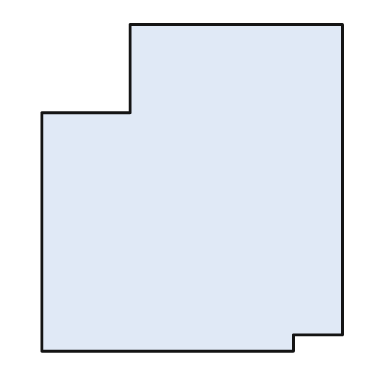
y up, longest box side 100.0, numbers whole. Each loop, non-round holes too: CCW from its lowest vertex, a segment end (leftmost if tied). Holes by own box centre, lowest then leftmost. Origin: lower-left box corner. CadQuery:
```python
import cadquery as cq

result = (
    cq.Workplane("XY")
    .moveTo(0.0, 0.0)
    .lineTo(77.0, 0.0)
    .lineTo(77.0, 5.0)
    .lineTo(92.0, 5.0)
    .lineTo(92.0, 100.0)
    .lineTo(27.0, 100.0)
    .lineTo(27.0, 73.0)
    .lineTo(0.0, 73.0)
    .close()
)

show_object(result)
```